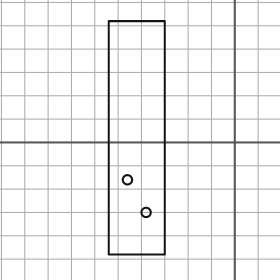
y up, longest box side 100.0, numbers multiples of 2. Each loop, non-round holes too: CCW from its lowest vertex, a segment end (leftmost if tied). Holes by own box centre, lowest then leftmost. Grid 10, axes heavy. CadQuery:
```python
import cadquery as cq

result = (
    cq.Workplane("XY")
    .moveTo(-54.0, -48.0)
    .lineTo(-30.0, -48.0)
    .lineTo(-30.0, 52.0)
    .lineTo(-54.0, 52.0)
    .close()
    .moveTo(-38.0, -30.0)
    .circle(2.0)
    .moveTo(-46.0, -16.0)
    .circle(2.0)
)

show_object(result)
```